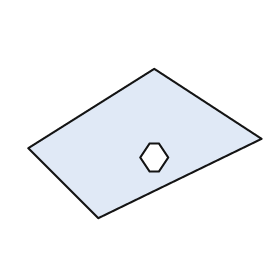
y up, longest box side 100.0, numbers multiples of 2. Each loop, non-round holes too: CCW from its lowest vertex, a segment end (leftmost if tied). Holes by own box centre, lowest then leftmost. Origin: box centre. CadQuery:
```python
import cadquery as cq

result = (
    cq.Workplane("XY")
    .moveTo(-20.0, -32.0)
    .lineTo(50.0, 2.0)
    .lineTo(4.0, 32.0)
    .lineTo(-50.0, -2.0)
    .close()
    .moveTo(2.0, -12.0)
    .lineTo(6.0, -12.0)
    .lineTo(10.0, -6.0)
    .lineTo(6.0, 0.0)
    .lineTo(2.0, 0.0)
    .lineTo(-2.0, -6.0)
    .close()
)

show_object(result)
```